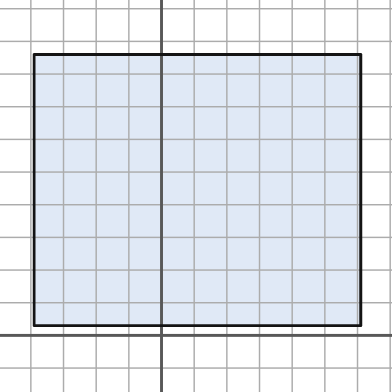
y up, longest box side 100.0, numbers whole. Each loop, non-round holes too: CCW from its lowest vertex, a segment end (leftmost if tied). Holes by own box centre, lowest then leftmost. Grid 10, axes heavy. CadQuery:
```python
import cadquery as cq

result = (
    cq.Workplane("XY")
    .moveTo(-39.0, 3.0)
    .lineTo(61.0, 3.0)
    .lineTo(61.0, 86.0)
    .lineTo(-39.0, 86.0)
    .close()
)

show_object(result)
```